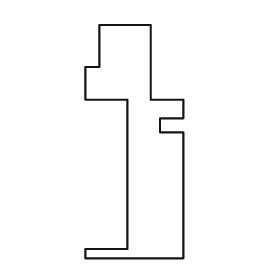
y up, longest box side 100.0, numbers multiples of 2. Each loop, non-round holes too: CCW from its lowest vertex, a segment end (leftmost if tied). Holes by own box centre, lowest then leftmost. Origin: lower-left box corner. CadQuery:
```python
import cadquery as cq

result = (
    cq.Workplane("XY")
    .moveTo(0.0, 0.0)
    .lineTo(42.0, 0.0)
    .lineTo(42.0, 54.0)
    .lineTo(32.0, 54.0)
    .lineTo(32.0, 60.0)
    .lineTo(42.0, 60.0)
    .lineTo(42.0, 68.0)
    .lineTo(28.0, 68.0)
    .lineTo(28.0, 100.0)
    .lineTo(6.0, 100.0)
    .lineTo(6.0, 82.0)
    .lineTo(0.0, 82.0)
    .lineTo(0.0, 68.0)
    .lineTo(18.0, 68.0)
    .lineTo(18.0, 4.0)
    .lineTo(0.0, 4.0)
    .close()
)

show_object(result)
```